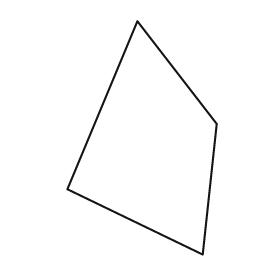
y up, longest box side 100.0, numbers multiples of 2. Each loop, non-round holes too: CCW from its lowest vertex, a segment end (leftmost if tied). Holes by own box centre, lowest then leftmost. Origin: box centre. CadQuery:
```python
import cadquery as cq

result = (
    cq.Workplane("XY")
    .moveTo(26.0, -50.0)
    .lineTo(32.0, 6.0)
    .lineTo(-2.0, 50.0)
    .lineTo(-32.0, -22.0)
    .close()
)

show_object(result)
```